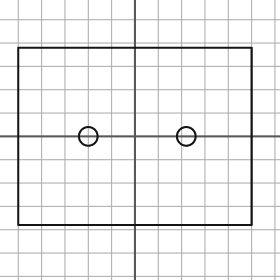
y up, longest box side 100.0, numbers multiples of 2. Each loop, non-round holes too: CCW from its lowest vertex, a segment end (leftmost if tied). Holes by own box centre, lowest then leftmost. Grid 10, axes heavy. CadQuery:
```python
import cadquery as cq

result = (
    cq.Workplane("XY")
    .moveTo(-50.0, -38.0)
    .lineTo(50.0, -38.0)
    .lineTo(50.0, 38.0)
    .lineTo(-50.0, 38.0)
    .close()
    .moveTo(-20.0, 0.0)
    .circle(4.0)
    .moveTo(22.0, 0.0)
    .circle(4.0)
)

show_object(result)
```